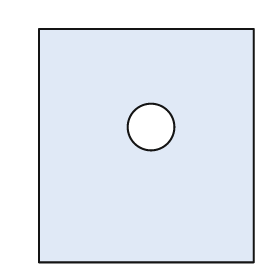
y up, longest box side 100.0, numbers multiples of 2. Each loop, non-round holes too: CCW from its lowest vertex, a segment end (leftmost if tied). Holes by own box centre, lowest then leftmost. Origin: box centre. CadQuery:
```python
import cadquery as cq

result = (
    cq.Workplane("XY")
    .moveTo(-46.0, -50.0)
    .lineTo(46.0, -50.0)
    .lineTo(46.0, 50.0)
    .lineTo(-46.0, 50.0)
    .close()
    .moveTo(2.0, 8.0)
    .circle(10.0)
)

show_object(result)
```